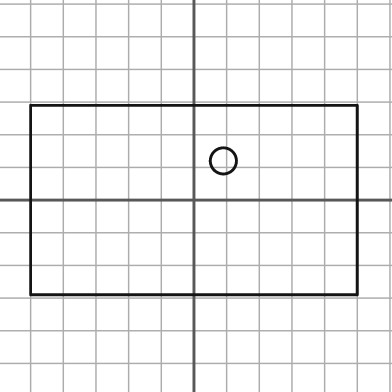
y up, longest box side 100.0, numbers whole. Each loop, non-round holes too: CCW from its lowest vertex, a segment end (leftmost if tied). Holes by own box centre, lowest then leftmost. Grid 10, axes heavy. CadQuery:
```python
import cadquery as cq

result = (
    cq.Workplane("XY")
    .moveTo(-50.0, -29.0)
    .lineTo(50.0, -29.0)
    .lineTo(50.0, 29.0)
    .lineTo(-50.0, 29.0)
    .close()
    .moveTo(9.0, 12.0)
    .circle(4.0)
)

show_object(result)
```